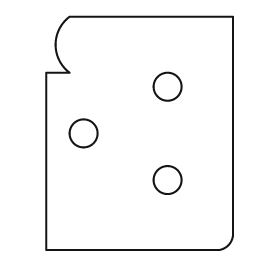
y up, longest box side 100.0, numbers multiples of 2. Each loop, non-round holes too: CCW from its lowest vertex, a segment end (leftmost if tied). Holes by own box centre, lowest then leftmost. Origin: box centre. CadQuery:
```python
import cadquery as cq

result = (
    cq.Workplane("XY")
    .moveTo(-40.0, -50.0)
    .lineTo(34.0, -50.0)
    .threePointArc((38.0, -48.0), (40.0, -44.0))
    .lineTo(40.0, 50.0)
    .lineTo(-30.0, 50.0)
    .threePointArc((-36.0, 38.0), (-30.0, 26.0))
    .lineTo(-40.0, 26.0)
    .close()
    .moveTo(12.0, -20.0)
    .circle(6.0)
    .moveTo(-24.0, 0.0)
    .circle(6.0)
    .moveTo(12.0, 20.0)
    .circle(6.0)
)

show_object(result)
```